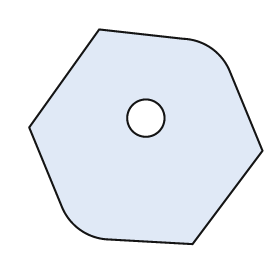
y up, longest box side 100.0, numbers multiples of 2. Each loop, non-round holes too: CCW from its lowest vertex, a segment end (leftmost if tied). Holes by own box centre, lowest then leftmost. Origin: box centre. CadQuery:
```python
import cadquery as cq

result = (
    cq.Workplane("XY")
    .moveTo(20.0, -46.0)
    .lineTo(50.0, -6.0)
    .lineTo(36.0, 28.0)
    .threePointArc((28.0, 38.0), (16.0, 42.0))
    .lineTo(-20.0, 46.0)
    .lineTo(-50.0, 4.0)
    .lineTo(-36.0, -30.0)
    .threePointArc((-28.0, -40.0), (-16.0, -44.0))
    .close()
    .moveTo(0.0, 8.0)
    .circle(8.0)
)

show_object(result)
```